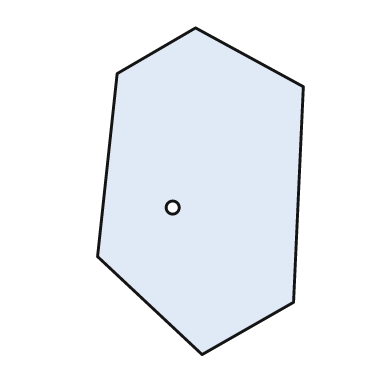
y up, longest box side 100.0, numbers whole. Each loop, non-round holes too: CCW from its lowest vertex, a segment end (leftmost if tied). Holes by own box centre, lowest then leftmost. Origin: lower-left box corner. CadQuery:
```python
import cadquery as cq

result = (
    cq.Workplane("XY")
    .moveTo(32.0, 0.0)
    .lineTo(60.0, 16.0)
    .lineTo(63.0, 82.0)
    .lineTo(30.0, 100.0)
    .lineTo(6.0, 86.0)
    .lineTo(0.0, 30.0)
    .close()
    .moveTo(23.0, 45.0)
    .circle(2.0)
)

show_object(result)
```